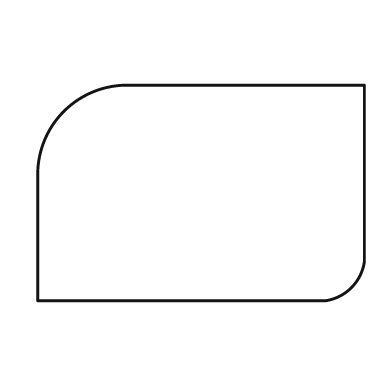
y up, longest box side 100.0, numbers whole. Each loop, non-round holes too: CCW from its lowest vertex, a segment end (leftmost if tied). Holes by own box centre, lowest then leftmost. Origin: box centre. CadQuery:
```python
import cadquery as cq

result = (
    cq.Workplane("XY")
    .moveTo(-50.0, -33.0)
    .lineTo(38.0, -33.0)
    .threePointArc((46.0, -29.0), (50.0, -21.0))
    .lineTo(50.0, 33.0)
    .lineTo(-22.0, 33.0)
    .threePointArc((-42.0, 25.0), (-50.0, 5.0))
    .close()
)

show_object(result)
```